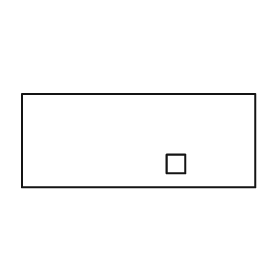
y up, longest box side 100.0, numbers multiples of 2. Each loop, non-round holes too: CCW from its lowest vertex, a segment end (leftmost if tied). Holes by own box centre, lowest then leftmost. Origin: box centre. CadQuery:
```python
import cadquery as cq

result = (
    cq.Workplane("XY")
    .moveTo(-50.0, -20.0)
    .lineTo(50.0, -20.0)
    .lineTo(50.0, 20.0)
    .lineTo(-50.0, 20.0)
    .close()
    .moveTo(12.0, -14.0)
    .lineTo(20.0, -14.0)
    .lineTo(20.0, -6.0)
    .lineTo(12.0, -6.0)
    .close()
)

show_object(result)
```